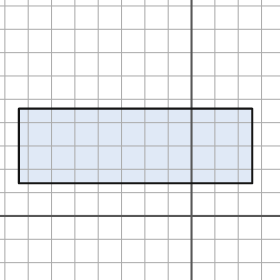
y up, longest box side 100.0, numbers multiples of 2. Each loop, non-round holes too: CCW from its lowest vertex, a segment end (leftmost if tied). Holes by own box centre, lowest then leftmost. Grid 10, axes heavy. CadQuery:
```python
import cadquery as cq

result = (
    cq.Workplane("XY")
    .moveTo(-74.0, 14.0)
    .lineTo(26.0, 14.0)
    .lineTo(26.0, 46.0)
    .lineTo(-74.0, 46.0)
    .close()
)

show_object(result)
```